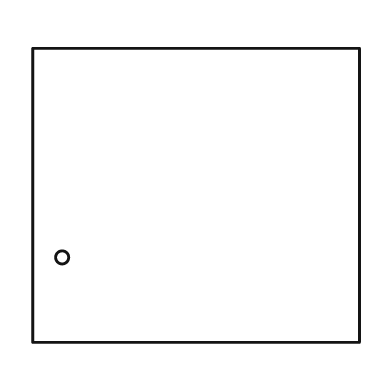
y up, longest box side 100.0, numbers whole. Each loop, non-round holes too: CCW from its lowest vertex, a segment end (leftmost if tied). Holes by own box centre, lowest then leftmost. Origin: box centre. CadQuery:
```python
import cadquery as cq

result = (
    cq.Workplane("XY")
    .moveTo(-50.0, -45.0)
    .lineTo(50.0, -45.0)
    .lineTo(50.0, 45.0)
    .lineTo(-50.0, 45.0)
    .close()
    .moveTo(-41.0, -19.0)
    .circle(2.0)
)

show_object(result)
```